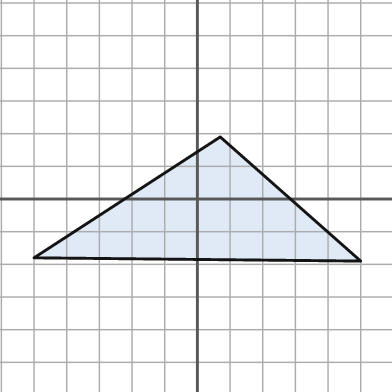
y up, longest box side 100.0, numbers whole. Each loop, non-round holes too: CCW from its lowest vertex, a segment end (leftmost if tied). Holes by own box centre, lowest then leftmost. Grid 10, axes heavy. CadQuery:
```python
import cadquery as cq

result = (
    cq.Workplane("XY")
    .moveTo(50.0, -19.0)
    .lineTo(7.0, 19.0)
    .lineTo(-50.0, -18.0)
    .close()
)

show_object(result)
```